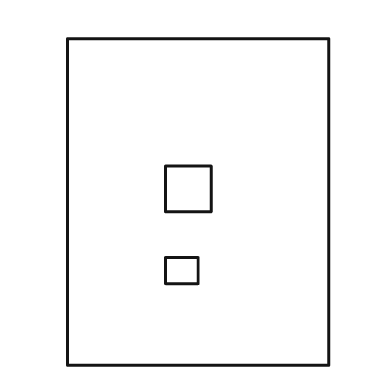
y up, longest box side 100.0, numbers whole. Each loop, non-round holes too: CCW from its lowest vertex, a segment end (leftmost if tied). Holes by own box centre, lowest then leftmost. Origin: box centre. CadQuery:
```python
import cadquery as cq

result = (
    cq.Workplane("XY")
    .moveTo(-40.0, -50.0)
    .lineTo(40.0, -50.0)
    .lineTo(40.0, 50.0)
    .lineTo(-40.0, 50.0)
    .close()
    .moveTo(-10.0, -25.0)
    .lineTo(0.0, -25.0)
    .lineTo(0.0, -17.0)
    .lineTo(-10.0, -17.0)
    .close()
    .moveTo(-10.0, -3.0)
    .lineTo(4.0, -3.0)
    .lineTo(4.0, 11.0)
    .lineTo(-10.0, 11.0)
    .close()
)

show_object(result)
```